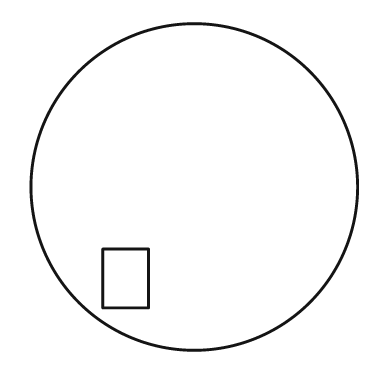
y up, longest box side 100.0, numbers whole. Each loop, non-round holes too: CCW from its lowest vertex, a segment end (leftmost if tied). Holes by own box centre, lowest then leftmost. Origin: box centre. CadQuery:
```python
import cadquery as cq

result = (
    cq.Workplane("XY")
    .moveTo(0.0, 0.0)
    .circle(50.0)
    .moveTo(-28.0, -37.0)
    .lineTo(-14.0, -37.0)
    .lineTo(-14.0, -19.0)
    .lineTo(-28.0, -19.0)
    .close()
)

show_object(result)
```